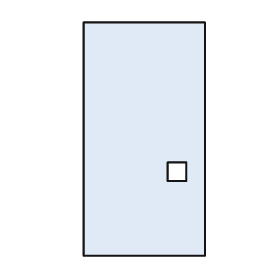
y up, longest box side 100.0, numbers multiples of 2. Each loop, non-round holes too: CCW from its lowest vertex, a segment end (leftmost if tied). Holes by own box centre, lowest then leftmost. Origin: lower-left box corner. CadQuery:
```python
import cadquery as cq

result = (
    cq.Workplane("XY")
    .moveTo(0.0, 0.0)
    .lineTo(52.0, 0.0)
    .lineTo(52.0, 100.0)
    .lineTo(0.0, 100.0)
    .close()
    .moveTo(36.0, 32.0)
    .lineTo(44.0, 32.0)
    .lineTo(44.0, 40.0)
    .lineTo(36.0, 40.0)
    .close()
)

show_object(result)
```